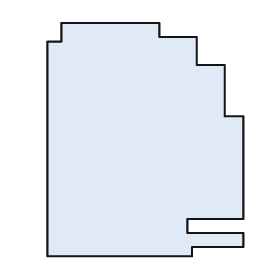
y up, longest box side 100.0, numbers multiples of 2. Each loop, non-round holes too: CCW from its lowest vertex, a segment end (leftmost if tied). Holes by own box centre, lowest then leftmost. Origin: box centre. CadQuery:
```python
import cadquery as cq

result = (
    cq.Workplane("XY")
    .moveTo(-42.0, -50.0)
    .lineTo(20.0, -50.0)
    .lineTo(20.0, -46.0)
    .lineTo(42.0, -46.0)
    .lineTo(42.0, -40.0)
    .lineTo(18.0, -40.0)
    .lineTo(18.0, -34.0)
    .lineTo(42.0, -34.0)
    .lineTo(42.0, 10.0)
    .lineTo(34.0, 10.0)
    .lineTo(34.0, 32.0)
    .lineTo(22.0, 32.0)
    .lineTo(22.0, 44.0)
    .lineTo(6.0, 44.0)
    .lineTo(6.0, 50.0)
    .lineTo(-36.0, 50.0)
    .lineTo(-36.0, 42.0)
    .lineTo(-42.0, 42.0)
    .close()
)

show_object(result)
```